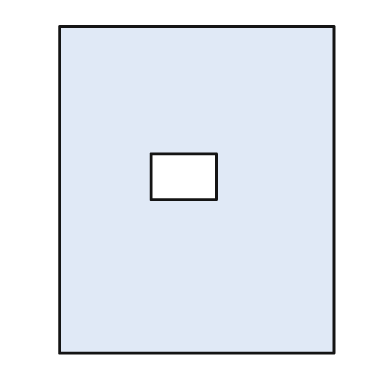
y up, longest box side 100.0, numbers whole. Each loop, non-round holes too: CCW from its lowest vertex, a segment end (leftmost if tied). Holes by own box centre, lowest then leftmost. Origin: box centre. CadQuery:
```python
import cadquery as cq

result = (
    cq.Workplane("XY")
    .moveTo(-42.0, -50.0)
    .lineTo(42.0, -50.0)
    .lineTo(42.0, 50.0)
    .lineTo(-42.0, 50.0)
    .close()
    .moveTo(-14.0, -3.0)
    .lineTo(6.0, -3.0)
    .lineTo(6.0, 11.0)
    .lineTo(-14.0, 11.0)
    .close()
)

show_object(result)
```